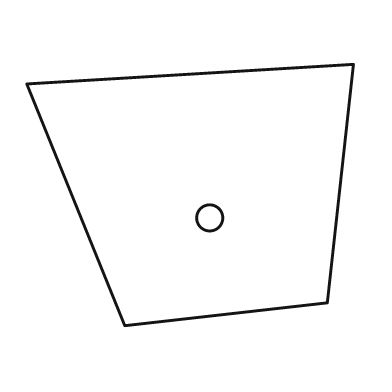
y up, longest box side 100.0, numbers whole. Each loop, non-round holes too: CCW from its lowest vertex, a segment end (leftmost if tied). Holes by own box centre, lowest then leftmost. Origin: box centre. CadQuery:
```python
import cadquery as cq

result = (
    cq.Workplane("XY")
    .moveTo(-20.0, -40.0)
    .lineTo(42.0, -33.0)
    .lineTo(50.0, 40.0)
    .lineTo(-50.0, 34.0)
    .close()
    .moveTo(6.0, -7.0)
    .circle(4.0)
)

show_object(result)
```